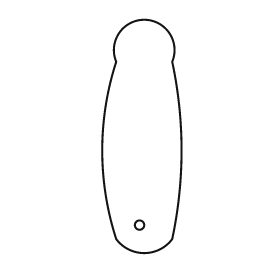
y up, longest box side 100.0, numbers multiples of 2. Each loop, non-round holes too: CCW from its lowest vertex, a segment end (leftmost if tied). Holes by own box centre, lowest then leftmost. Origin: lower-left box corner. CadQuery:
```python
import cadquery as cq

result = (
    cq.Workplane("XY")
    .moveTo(6.0, 6.0)
    .threePointArc((18.0, 0.0), (30.0, 6.0))
    .threePointArc((34.0, 44.0), (30.0, 82.0))
    .threePointArc((18.0, 100.0), (6.0, 82.0))
    .threePointArc((0.0, 44.0), (6.0, 6.0))
    .close()
    .moveTo(16.0, 12.0)
    .circle(2.0)
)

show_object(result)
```